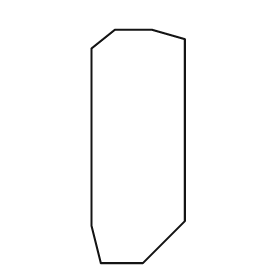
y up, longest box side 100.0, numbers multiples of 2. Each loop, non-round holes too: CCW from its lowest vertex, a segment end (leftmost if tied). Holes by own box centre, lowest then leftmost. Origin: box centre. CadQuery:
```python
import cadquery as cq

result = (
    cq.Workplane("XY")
    .moveTo(-16.0, -50.0)
    .lineTo(2.0, -50.0)
    .lineTo(20.0, -32.0)
    .lineTo(20.0, 46.0)
    .lineTo(6.0, 50.0)
    .lineTo(-10.0, 50.0)
    .lineTo(-20.0, 42.0)
    .lineTo(-20.0, -34.0)
    .close()
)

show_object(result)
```